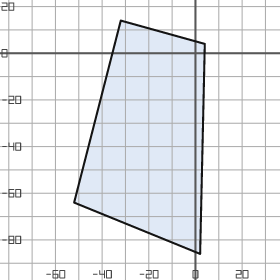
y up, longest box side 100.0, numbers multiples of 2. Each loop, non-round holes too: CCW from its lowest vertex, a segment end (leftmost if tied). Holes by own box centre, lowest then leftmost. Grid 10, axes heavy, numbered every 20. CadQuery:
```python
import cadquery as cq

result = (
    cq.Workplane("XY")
    .moveTo(2.0, -86.0)
    .lineTo(4.0, 4.0)
    .lineTo(-32.0, 14.0)
    .lineTo(-52.0, -64.0)
    .close()
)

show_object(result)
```